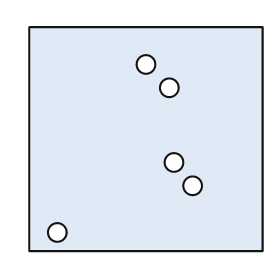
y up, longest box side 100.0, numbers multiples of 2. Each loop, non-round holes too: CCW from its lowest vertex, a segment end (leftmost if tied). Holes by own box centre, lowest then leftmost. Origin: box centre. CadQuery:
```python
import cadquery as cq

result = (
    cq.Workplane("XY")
    .moveTo(-50.0, -48.0)
    .lineTo(50.0, -48.0)
    .lineTo(50.0, 48.0)
    .lineTo(-50.0, 48.0)
    .close()
    .moveTo(-38.0, -40.0)
    .circle(4.0)
    .moveTo(20.0, -20.0)
    .circle(4.0)
    .moveTo(12.0, -10.0)
    .circle(4.0)
    .moveTo(10.0, 22.0)
    .circle(4.0)
    .moveTo(0.0, 32.0)
    .circle(4.0)
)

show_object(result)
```